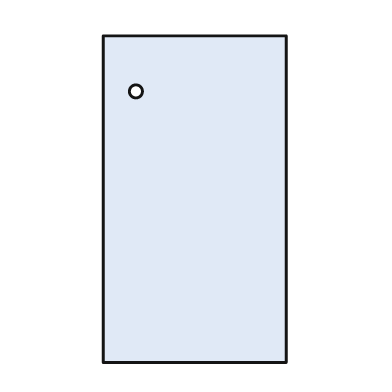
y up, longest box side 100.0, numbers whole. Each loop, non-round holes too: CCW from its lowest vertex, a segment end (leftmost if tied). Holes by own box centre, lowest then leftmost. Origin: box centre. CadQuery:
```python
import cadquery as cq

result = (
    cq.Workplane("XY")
    .moveTo(-28.0, -50.0)
    .lineTo(28.0, -50.0)
    .lineTo(28.0, 50.0)
    .lineTo(-28.0, 50.0)
    .close()
    .moveTo(-18.0, 33.0)
    .circle(2.0)
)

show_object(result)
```